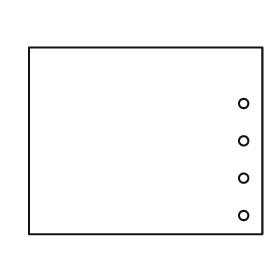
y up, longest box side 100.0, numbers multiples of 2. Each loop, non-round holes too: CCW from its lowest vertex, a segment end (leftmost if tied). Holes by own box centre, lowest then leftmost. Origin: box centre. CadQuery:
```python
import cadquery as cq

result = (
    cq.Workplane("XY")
    .moveTo(-50.0, -40.0)
    .lineTo(50.0, -40.0)
    .lineTo(50.0, 40.0)
    .lineTo(-50.0, 40.0)
    .close()
    .moveTo(42.0, -32.0)
    .circle(2.0)
    .moveTo(42.0, -16.0)
    .circle(2.0)
    .moveTo(42.0, 0.0)
    .circle(2.0)
    .moveTo(42.0, 16.0)
    .circle(2.0)
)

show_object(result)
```